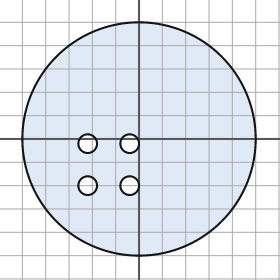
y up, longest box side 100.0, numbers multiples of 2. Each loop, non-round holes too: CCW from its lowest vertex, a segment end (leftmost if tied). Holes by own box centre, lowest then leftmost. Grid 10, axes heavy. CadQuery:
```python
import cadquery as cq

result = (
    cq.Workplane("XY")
    .moveTo(0.0, 0.0)
    .circle(50.0)
    .moveTo(-22.0, -20.0)
    .circle(4.0)
    .moveTo(-4.0, -20.0)
    .circle(4.0)
    .moveTo(-22.0, -2.0)
    .circle(4.0)
    .moveTo(-4.0, -2.0)
    .circle(4.0)
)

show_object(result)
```